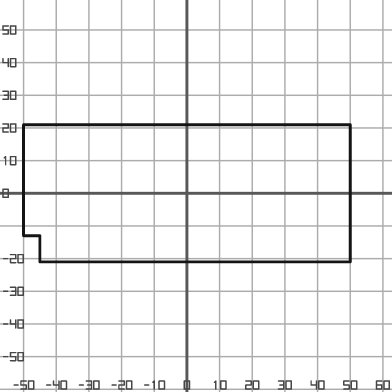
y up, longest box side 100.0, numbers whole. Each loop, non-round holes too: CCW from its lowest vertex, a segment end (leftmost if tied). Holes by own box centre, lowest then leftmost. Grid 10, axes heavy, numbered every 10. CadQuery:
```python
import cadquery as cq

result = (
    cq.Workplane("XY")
    .moveTo(-45.0, -21.0)
    .lineTo(50.0, -21.0)
    .lineTo(50.0, 21.0)
    .lineTo(-50.0, 21.0)
    .lineTo(-50.0, -13.0)
    .lineTo(-45.0, -13.0)
    .close()
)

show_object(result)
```